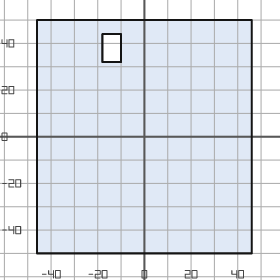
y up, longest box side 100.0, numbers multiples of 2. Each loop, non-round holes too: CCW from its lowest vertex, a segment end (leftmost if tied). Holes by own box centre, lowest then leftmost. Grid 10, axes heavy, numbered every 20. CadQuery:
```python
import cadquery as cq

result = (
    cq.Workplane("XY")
    .moveTo(-46.0, -50.0)
    .lineTo(46.0, -50.0)
    .lineTo(46.0, 50.0)
    .lineTo(-46.0, 50.0)
    .close()
    .moveTo(-18.0, 32.0)
    .lineTo(-10.0, 32.0)
    .lineTo(-10.0, 44.0)
    .lineTo(-18.0, 44.0)
    .close()
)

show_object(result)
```